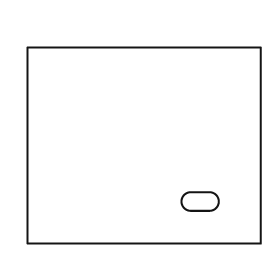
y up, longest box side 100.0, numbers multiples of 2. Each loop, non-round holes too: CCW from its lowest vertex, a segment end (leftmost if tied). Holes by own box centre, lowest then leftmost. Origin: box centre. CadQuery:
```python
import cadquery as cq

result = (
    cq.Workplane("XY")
    .moveTo(-50.0, -42.0)
    .lineTo(50.0, -42.0)
    .lineTo(50.0, 42.0)
    .lineTo(-50.0, 42.0)
    .close()
    .moveTo(20.0, -28.0)
    .lineTo(28.0, -28.0)
    .threePointArc((32.0, -24.0), (28.0, -20.0))
    .lineTo(20.0, -20.0)
    .threePointArc((16.0, -24.0), (20.0, -28.0))
    .close()
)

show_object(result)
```